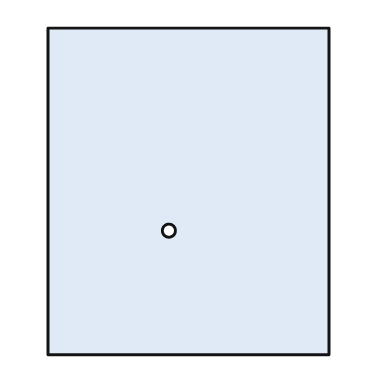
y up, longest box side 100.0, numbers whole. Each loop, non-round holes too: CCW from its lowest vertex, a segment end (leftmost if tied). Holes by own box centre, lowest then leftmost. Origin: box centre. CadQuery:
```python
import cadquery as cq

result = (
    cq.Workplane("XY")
    .moveTo(-43.0, -50.0)
    .lineTo(43.0, -50.0)
    .lineTo(43.0, 50.0)
    .lineTo(-43.0, 50.0)
    .close()
    .moveTo(-6.0, -12.0)
    .circle(2.0)
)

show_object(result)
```